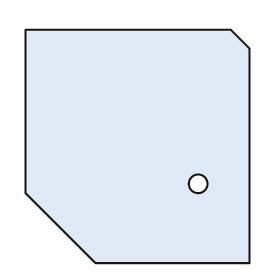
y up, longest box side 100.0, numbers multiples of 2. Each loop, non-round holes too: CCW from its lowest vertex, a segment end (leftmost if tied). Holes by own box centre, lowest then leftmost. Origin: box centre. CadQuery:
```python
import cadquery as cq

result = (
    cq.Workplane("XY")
    .moveTo(-18.0, -50.0)
    .lineTo(48.0, -50.0)
    .lineTo(48.0, 42.0)
    .lineTo(40.0, 50.0)
    .lineTo(-48.0, 50.0)
    .lineTo(-48.0, -20.0)
    .close()
    .moveTo(26.0, -16.0)
    .circle(4.0)
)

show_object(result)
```